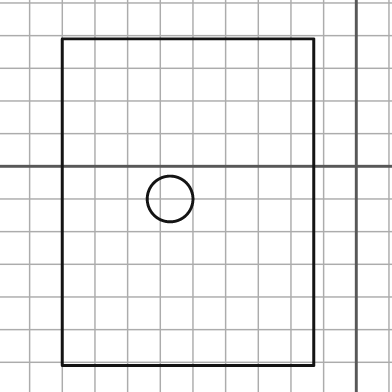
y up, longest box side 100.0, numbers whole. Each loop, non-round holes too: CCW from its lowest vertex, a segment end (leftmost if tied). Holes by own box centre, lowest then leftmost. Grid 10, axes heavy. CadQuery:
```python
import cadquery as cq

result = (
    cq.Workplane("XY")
    .moveTo(-90.0, -61.0)
    .lineTo(-13.0, -61.0)
    .lineTo(-13.0, 39.0)
    .lineTo(-90.0, 39.0)
    .close()
    .moveTo(-57.0, -10.0)
    .circle(7.0)
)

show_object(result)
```